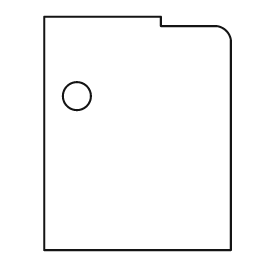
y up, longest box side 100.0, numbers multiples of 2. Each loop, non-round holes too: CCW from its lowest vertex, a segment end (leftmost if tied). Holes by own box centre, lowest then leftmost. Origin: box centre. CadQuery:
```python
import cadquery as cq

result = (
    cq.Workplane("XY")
    .moveTo(-40.0, -50.0)
    .lineTo(40.0, -50.0)
    .lineTo(40.0, 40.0)
    .threePointArc((38.0, 44.0), (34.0, 46.0))
    .lineTo(10.0, 46.0)
    .lineTo(10.0, 50.0)
    .lineTo(-40.0, 50.0)
    .close()
    .moveTo(-26.0, 16.0)
    .circle(6.0)
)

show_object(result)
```